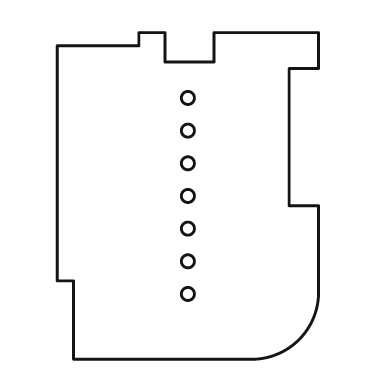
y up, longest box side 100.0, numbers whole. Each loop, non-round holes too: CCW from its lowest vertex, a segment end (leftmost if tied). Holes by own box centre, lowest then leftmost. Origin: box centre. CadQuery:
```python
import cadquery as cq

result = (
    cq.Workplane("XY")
    .moveTo(-35.0, -50.0)
    .lineTo(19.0, -50.0)
    .threePointArc((34.0, -44.0), (40.0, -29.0))
    .lineTo(40.0, -3.0)
    .lineTo(31.0, -3.0)
    .lineTo(31.0, 39.0)
    .lineTo(40.0, 39.0)
    .lineTo(40.0, 50.0)
    .lineTo(8.0, 50.0)
    .lineTo(8.0, 41.0)
    .lineTo(-7.0, 41.0)
    .lineTo(-7.0, 50.0)
    .lineTo(-15.0, 50.0)
    .lineTo(-15.0, 46.0)
    .lineTo(-40.0, 46.0)
    .lineTo(-40.0, -26.0)
    .lineTo(-35.0, -26.0)
    .close()
    .moveTo(0.0, -30.0)
    .circle(2.0)
    .moveTo(0.0, -20.0)
    .circle(2.0)
    .moveTo(0.0, -10.0)
    .circle(2.0)
    .moveTo(0.0, 0.0)
    .circle(2.0)
    .moveTo(0.0, 10.0)
    .circle(2.0)
    .moveTo(0.0, 20.0)
    .circle(2.0)
    .moveTo(0.0, 30.0)
    .circle(2.0)
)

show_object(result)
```